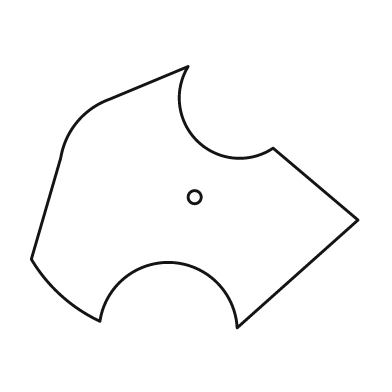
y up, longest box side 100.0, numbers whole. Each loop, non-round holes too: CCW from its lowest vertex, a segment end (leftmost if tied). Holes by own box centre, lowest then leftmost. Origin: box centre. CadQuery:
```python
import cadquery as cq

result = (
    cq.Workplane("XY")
    .moveTo(13.0, -40.0)
    .lineTo(50.0, -7.0)
    .lineTo(24.0, 15.0)
    .threePointArc((1.0, 17.0), (-2.0, 40.0))
    .lineTo(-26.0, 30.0)
    .threePointArc((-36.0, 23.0), (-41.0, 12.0))
    .lineTo(-50.0, -19.0)
    .threePointArc((-41.0, -30.0), (-29.0, -38.0))
    .threePointArc((-7.0, -20.0), (13.0, -40.0))
    .close()
    .moveTo(0.0, 0.0)
    .circle(2.0)
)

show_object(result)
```